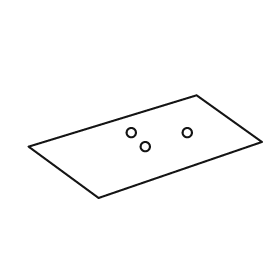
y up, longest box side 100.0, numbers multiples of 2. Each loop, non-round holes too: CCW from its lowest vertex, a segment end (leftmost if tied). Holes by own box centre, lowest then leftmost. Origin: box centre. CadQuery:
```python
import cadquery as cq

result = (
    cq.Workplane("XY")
    .moveTo(-20.0, -22.0)
    .lineTo(50.0, 2.0)
    .lineTo(22.0, 22.0)
    .lineTo(-50.0, 0.0)
    .close()
    .moveTo(0.0, 0.0)
    .circle(2.0)
    .moveTo(-6.0, 6.0)
    .circle(2.0)
    .moveTo(18.0, 6.0)
    .circle(2.0)
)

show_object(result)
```